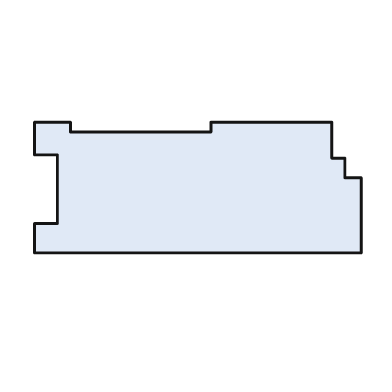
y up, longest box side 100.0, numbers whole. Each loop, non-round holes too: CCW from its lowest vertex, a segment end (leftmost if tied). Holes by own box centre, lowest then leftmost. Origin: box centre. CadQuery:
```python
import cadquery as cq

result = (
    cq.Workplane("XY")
    .moveTo(-50.0, -20.0)
    .lineTo(50.0, -20.0)
    .lineTo(50.0, 3.0)
    .lineTo(45.0, 3.0)
    .lineTo(45.0, 9.0)
    .lineTo(41.0, 9.0)
    .lineTo(41.0, 20.0)
    .lineTo(4.0, 20.0)
    .lineTo(4.0, 17.0)
    .lineTo(-39.0, 17.0)
    .lineTo(-39.0, 20.0)
    .lineTo(-50.0, 20.0)
    .lineTo(-50.0, 10.0)
    .lineTo(-43.0, 10.0)
    .lineTo(-43.0, -11.0)
    .lineTo(-50.0, -11.0)
    .close()
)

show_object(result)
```